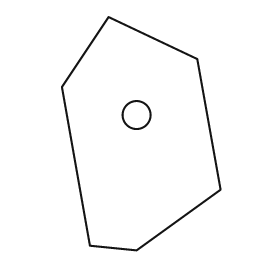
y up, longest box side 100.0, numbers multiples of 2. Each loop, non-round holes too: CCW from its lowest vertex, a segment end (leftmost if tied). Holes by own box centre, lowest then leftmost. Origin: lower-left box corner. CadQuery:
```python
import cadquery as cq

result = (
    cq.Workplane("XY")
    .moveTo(32.0, 0.0)
    .lineTo(68.0, 26.0)
    .lineTo(58.0, 82.0)
    .lineTo(20.0, 100.0)
    .lineTo(0.0, 70.0)
    .lineTo(12.0, 2.0)
    .close()
    .moveTo(32.0, 58.0)
    .circle(6.0)
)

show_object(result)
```